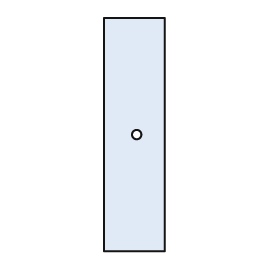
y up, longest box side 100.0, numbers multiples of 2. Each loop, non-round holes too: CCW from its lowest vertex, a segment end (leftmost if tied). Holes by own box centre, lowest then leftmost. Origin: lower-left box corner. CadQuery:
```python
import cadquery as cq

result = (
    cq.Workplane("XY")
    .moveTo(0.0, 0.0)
    .lineTo(26.0, 0.0)
    .lineTo(26.0, 100.0)
    .lineTo(0.0, 100.0)
    .close()
    .moveTo(14.0, 50.0)
    .circle(2.0)
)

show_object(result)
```